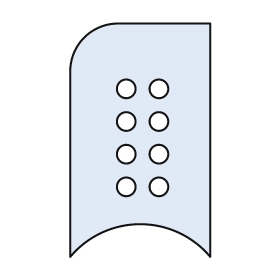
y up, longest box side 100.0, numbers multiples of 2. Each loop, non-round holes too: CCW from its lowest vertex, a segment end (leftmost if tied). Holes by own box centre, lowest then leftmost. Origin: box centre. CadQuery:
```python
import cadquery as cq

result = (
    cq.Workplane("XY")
    .moveTo(-30.0, -50.0)
    .threePointArc((0.0, -36.0), (30.0, -50.0))
    .lineTo(30.0, 50.0)
    .lineTo(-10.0, 50.0)
    .threePointArc((-24.0, 44.0), (-30.0, 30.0))
    .close()
    .moveTo(-6.0, -20.0)
    .circle(4.0)
    .moveTo(8.0, -20.0)
    .circle(4.0)
    .moveTo(-6.0, -6.0)
    .circle(4.0)
    .moveTo(8.0, -6.0)
    .circle(4.0)
    .moveTo(-6.0, 8.0)
    .circle(4.0)
    .moveTo(8.0, 8.0)
    .circle(4.0)
    .moveTo(-6.0, 22.0)
    .circle(4.0)
    .moveTo(8.0, 22.0)
    .circle(4.0)
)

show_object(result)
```